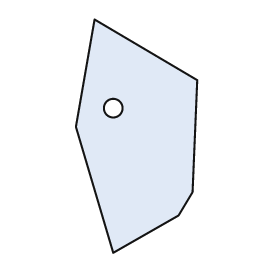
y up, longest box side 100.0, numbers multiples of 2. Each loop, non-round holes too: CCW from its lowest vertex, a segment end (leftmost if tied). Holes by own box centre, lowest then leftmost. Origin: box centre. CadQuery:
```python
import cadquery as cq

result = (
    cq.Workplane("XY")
    .moveTo(-10.0, -50.0)
    .lineTo(18.0, -34.0)
    .lineTo(24.0, -24.0)
    .lineTo(26.0, 24.0)
    .lineTo(-18.0, 50.0)
    .lineTo(-26.0, 4.0)
    .close()
    .moveTo(-10.0, 12.0)
    .circle(4.0)
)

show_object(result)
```